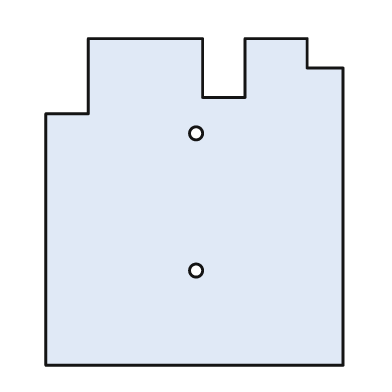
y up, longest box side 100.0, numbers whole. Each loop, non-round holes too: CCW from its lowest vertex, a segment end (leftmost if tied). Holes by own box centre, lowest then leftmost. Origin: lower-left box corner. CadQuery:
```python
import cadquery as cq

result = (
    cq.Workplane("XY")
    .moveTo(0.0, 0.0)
    .lineTo(91.0, 0.0)
    .lineTo(91.0, 91.0)
    .lineTo(80.0, 91.0)
    .lineTo(80.0, 100.0)
    .lineTo(61.0, 100.0)
    .lineTo(61.0, 82.0)
    .lineTo(48.0, 82.0)
    .lineTo(48.0, 100.0)
    .lineTo(13.0, 100.0)
    .lineTo(13.0, 77.0)
    .lineTo(0.0, 77.0)
    .close()
    .moveTo(46.0, 29.0)
    .circle(2.0)
    .moveTo(46.0, 71.0)
    .circle(2.0)
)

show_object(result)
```